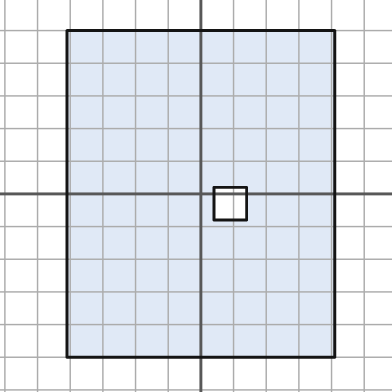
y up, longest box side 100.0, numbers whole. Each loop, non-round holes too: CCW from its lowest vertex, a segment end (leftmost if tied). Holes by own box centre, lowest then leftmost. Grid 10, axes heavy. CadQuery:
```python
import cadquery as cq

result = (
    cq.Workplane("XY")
    .moveTo(-41.0, -50.0)
    .lineTo(41.0, -50.0)
    .lineTo(41.0, 50.0)
    .lineTo(-41.0, 50.0)
    .close()
    .moveTo(4.0, -8.0)
    .lineTo(14.0, -8.0)
    .lineTo(14.0, 2.0)
    .lineTo(4.0, 2.0)
    .close()
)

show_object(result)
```